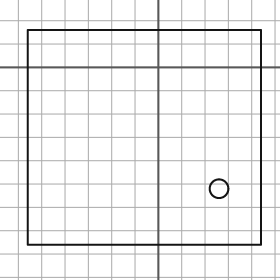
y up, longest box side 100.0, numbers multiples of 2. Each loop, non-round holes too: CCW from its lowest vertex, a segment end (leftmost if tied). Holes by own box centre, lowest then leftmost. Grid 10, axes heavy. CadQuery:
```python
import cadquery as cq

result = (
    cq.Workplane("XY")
    .moveTo(-56.0, -76.0)
    .lineTo(44.0, -76.0)
    .lineTo(44.0, 16.0)
    .lineTo(-56.0, 16.0)
    .close()
    .moveTo(26.0, -52.0)
    .circle(4.0)
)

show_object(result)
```